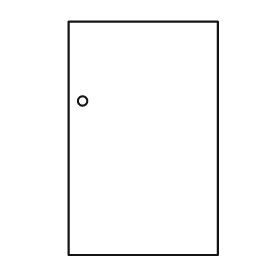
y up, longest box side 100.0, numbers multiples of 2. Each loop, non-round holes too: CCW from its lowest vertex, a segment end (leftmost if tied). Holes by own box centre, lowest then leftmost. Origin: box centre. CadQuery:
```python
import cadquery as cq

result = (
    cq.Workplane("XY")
    .moveTo(-32.0, -50.0)
    .lineTo(32.0, -50.0)
    .lineTo(32.0, 50.0)
    .lineTo(-32.0, 50.0)
    .close()
    .moveTo(-26.0, 16.0)
    .circle(2.0)
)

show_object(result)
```